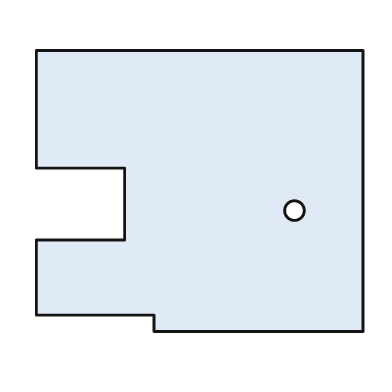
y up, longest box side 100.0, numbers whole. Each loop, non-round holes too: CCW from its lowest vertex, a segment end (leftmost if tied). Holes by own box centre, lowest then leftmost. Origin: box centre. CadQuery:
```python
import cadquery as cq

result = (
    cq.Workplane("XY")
    .moveTo(-14.0, -43.0)
    .lineTo(50.0, -43.0)
    .lineTo(50.0, 43.0)
    .lineTo(-50.0, 43.0)
    .lineTo(-50.0, 7.0)
    .lineTo(-23.0, 7.0)
    .lineTo(-23.0, -15.0)
    .lineTo(-50.0, -15.0)
    .lineTo(-50.0, -38.0)
    .lineTo(-14.0, -38.0)
    .close()
    .moveTo(29.0, -6.0)
    .circle(3.0)
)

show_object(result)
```